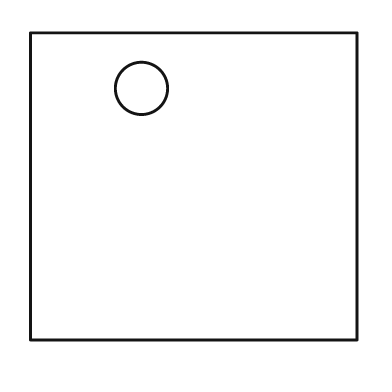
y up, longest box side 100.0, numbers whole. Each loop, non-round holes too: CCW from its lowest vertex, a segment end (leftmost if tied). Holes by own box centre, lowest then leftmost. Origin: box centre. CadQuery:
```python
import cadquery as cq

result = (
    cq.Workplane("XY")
    .moveTo(-50.0, -47.0)
    .lineTo(50.0, -47.0)
    .lineTo(50.0, 47.0)
    .lineTo(-50.0, 47.0)
    .close()
    .moveTo(-16.0, 30.0)
    .circle(8.0)
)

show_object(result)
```